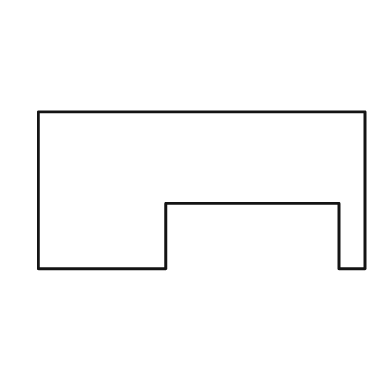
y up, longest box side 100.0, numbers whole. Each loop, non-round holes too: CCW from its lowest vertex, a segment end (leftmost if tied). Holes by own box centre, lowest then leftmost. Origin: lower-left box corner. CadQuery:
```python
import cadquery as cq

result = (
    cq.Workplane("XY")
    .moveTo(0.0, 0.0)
    .lineTo(39.0, 0.0)
    .lineTo(39.0, 20.0)
    .lineTo(92.0, 20.0)
    .lineTo(92.0, 0.0)
    .lineTo(100.0, 0.0)
    .lineTo(100.0, 48.0)
    .lineTo(0.0, 48.0)
    .close()
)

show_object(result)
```